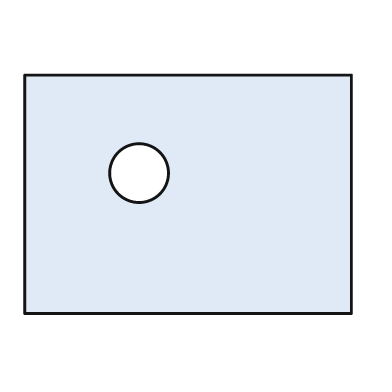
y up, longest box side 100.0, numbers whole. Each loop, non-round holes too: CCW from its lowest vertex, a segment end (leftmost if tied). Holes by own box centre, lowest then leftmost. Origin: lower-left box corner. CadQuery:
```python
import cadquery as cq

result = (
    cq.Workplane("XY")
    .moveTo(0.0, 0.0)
    .lineTo(100.0, 0.0)
    .lineTo(100.0, 73.0)
    .lineTo(0.0, 73.0)
    .close()
    .moveTo(35.0, 43.0)
    .circle(9.0)
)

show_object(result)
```